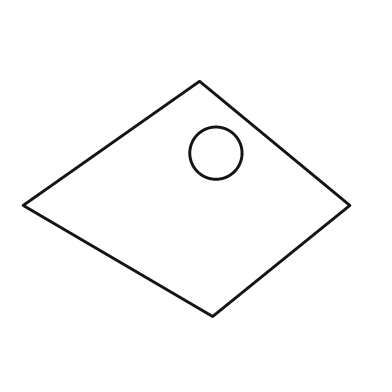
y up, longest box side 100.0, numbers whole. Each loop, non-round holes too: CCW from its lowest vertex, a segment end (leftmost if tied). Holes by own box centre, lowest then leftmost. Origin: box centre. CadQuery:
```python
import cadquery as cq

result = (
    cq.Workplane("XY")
    .moveTo(8.0, -36.0)
    .lineTo(50.0, -2.0)
    .lineTo(4.0, 36.0)
    .lineTo(-50.0, -2.0)
    .close()
    .moveTo(9.0, 14.0)
    .circle(8.0)
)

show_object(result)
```